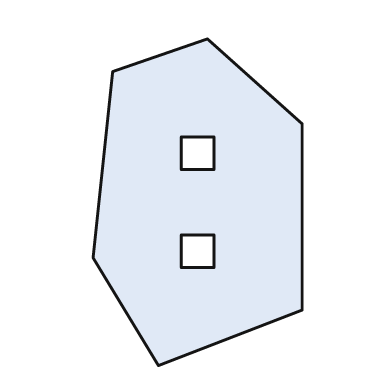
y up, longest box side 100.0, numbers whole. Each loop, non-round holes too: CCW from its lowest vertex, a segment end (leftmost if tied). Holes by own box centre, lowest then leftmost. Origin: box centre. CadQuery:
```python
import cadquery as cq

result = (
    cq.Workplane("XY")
    .moveTo(-12.0, -50.0)
    .lineTo(32.0, -33.0)
    .lineTo(32.0, 24.0)
    .lineTo(3.0, 50.0)
    .lineTo(-26.0, 40.0)
    .lineTo(-32.0, -17.0)
    .close()
    .moveTo(-5.0, -20.0)
    .lineTo(5.0, -20.0)
    .lineTo(5.0, -10.0)
    .lineTo(-5.0, -10.0)
    .close()
    .moveTo(-5.0, 10.0)
    .lineTo(5.0, 10.0)
    .lineTo(5.0, 20.0)
    .lineTo(-5.0, 20.0)
    .close()
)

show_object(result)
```